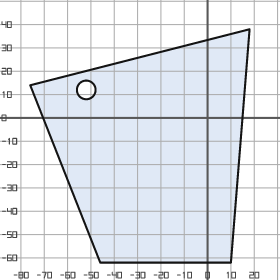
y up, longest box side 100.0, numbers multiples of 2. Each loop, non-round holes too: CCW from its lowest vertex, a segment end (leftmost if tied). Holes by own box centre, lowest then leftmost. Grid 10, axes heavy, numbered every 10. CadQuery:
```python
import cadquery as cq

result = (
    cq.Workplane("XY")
    .moveTo(-46.0, -62.0)
    .lineTo(10.0, -62.0)
    .lineTo(18.0, 38.0)
    .lineTo(-76.0, 14.0)
    .close()
    .moveTo(-52.0, 12.0)
    .circle(4.0)
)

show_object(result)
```